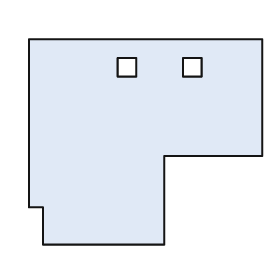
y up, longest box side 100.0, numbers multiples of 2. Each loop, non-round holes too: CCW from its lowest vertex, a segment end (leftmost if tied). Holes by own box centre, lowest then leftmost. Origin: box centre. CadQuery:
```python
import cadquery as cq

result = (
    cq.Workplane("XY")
    .moveTo(-44.0, -44.0)
    .lineTo(8.0, -44.0)
    .lineTo(8.0, -6.0)
    .lineTo(50.0, -6.0)
    .lineTo(50.0, 44.0)
    .lineTo(-50.0, 44.0)
    .lineTo(-50.0, -28.0)
    .lineTo(-44.0, -28.0)
    .close()
    .moveTo(-12.0, 28.0)
    .lineTo(-4.0, 28.0)
    .lineTo(-4.0, 36.0)
    .lineTo(-12.0, 36.0)
    .close()
    .moveTo(16.0, 28.0)
    .lineTo(24.0, 28.0)
    .lineTo(24.0, 36.0)
    .lineTo(16.0, 36.0)
    .close()
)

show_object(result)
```